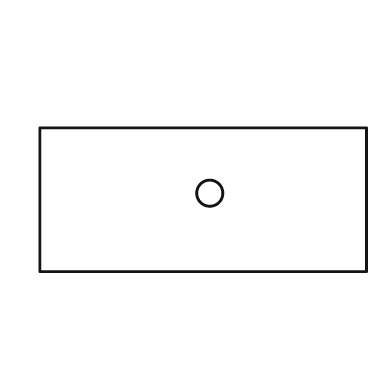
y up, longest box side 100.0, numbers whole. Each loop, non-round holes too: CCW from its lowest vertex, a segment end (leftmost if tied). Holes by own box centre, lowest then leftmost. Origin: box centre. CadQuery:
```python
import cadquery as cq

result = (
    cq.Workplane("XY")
    .moveTo(-50.0, -22.0)
    .lineTo(50.0, -22.0)
    .lineTo(50.0, 22.0)
    .lineTo(-50.0, 22.0)
    .close()
    .moveTo(2.0, 2.0)
    .circle(4.0)
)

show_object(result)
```